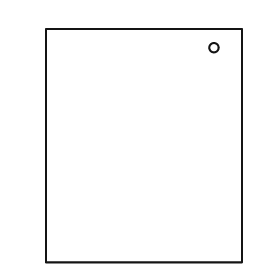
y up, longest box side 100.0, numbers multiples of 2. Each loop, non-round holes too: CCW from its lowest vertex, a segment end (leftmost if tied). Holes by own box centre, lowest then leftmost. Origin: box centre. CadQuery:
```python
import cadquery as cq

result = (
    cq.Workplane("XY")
    .moveTo(-42.0, -50.0)
    .lineTo(42.0, -50.0)
    .lineTo(42.0, 50.0)
    .lineTo(-42.0, 50.0)
    .close()
    .moveTo(30.0, 42.0)
    .circle(2.0)
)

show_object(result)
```